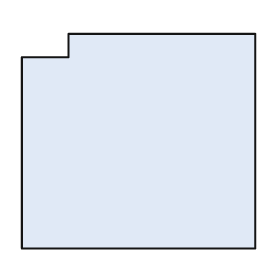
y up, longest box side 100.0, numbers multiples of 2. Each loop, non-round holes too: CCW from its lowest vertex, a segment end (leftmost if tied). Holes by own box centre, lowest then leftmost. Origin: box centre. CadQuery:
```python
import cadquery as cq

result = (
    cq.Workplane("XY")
    .moveTo(-50.0, -46.0)
    .lineTo(50.0, -46.0)
    .lineTo(50.0, 46.0)
    .lineTo(-30.0, 46.0)
    .lineTo(-30.0, 36.0)
    .lineTo(-50.0, 36.0)
    .close()
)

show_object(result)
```